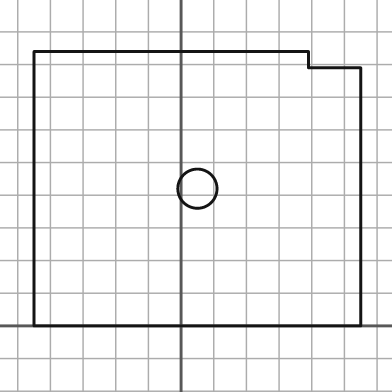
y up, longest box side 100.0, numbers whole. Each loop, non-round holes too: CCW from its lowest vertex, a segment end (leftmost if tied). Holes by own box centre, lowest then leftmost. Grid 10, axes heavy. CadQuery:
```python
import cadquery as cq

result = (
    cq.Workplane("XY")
    .moveTo(-45.0, 0.0)
    .lineTo(55.0, 0.0)
    .lineTo(55.0, 79.0)
    .lineTo(39.0, 79.0)
    .lineTo(39.0, 84.0)
    .lineTo(-45.0, 84.0)
    .close()
    .moveTo(5.0, 42.0)
    .circle(6.0)
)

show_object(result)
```